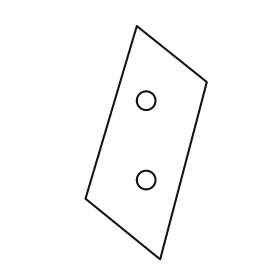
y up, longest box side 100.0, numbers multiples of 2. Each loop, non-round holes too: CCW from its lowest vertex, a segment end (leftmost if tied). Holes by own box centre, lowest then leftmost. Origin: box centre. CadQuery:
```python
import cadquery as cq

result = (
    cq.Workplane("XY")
    .moveTo(6.0, -50.0)
    .lineTo(26.0, 26.0)
    .lineTo(-4.0, 50.0)
    .lineTo(-26.0, -24.0)
    .close()
    .moveTo(0.0, -16.0)
    .circle(4.0)
    .moveTo(0.0, 18.0)
    .circle(4.0)
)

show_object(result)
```